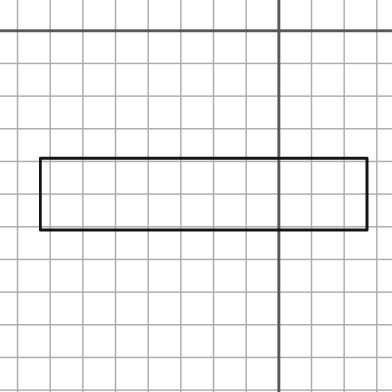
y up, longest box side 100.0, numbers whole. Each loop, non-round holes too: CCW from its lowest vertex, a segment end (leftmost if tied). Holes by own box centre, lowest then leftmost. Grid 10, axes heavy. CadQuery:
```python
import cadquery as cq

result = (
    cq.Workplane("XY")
    .moveTo(-73.0, -61.0)
    .lineTo(27.0, -61.0)
    .lineTo(27.0, -39.0)
    .lineTo(-73.0, -39.0)
    .close()
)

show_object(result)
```